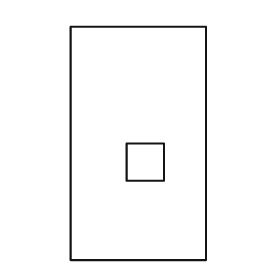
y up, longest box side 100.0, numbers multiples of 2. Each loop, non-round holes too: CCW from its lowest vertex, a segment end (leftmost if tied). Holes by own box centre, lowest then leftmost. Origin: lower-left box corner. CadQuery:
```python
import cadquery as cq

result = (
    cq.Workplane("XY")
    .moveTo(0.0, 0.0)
    .lineTo(58.0, 0.0)
    .lineTo(58.0, 100.0)
    .lineTo(0.0, 100.0)
    .close()
    .moveTo(24.0, 34.0)
    .lineTo(40.0, 34.0)
    .lineTo(40.0, 50.0)
    .lineTo(24.0, 50.0)
    .close()
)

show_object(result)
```